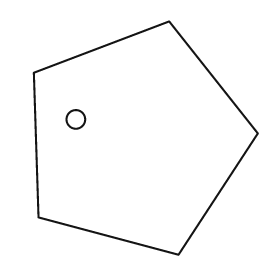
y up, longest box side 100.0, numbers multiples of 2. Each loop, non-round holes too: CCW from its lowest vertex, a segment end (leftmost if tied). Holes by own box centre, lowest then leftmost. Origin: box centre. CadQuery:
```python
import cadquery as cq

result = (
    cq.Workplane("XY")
    .moveTo(14.0, -50.0)
    .lineTo(48.0, 2.0)
    .lineTo(10.0, 50.0)
    .lineTo(-48.0, 28.0)
    .lineTo(-46.0, -34.0)
    .close()
    .moveTo(-30.0, 8.0)
    .circle(4.0)
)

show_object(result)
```